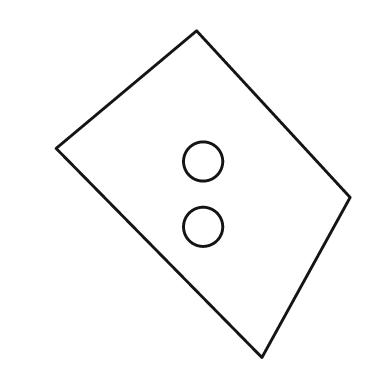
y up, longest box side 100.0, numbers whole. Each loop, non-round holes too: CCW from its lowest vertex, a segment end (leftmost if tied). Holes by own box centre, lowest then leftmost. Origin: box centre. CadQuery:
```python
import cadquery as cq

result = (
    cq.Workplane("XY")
    .moveTo(18.0, -50.0)
    .lineTo(45.0, -1.0)
    .lineTo(-2.0, 50.0)
    .lineTo(-45.0, 14.0)
    .close()
    .moveTo(0.0, -10.0)
    .circle(6.0)
    .moveTo(0.0, 10.0)
    .circle(6.0)
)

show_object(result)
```